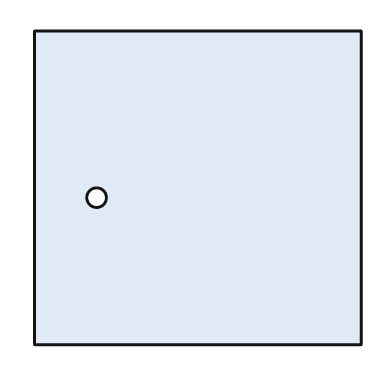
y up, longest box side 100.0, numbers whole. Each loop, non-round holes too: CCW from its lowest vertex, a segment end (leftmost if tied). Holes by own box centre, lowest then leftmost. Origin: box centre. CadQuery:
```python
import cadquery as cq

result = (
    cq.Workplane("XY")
    .moveTo(-50.0, -48.0)
    .lineTo(50.0, -48.0)
    .lineTo(50.0, 48.0)
    .lineTo(-50.0, 48.0)
    .close()
    .moveTo(-31.0, -3.0)
    .circle(3.0)
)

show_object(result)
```